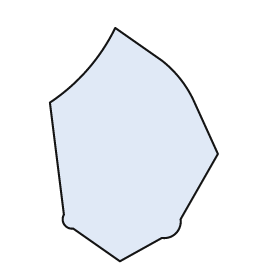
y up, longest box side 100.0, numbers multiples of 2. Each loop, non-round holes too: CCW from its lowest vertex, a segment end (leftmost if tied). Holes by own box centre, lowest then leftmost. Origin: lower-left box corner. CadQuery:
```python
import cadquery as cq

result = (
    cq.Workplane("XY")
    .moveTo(30.0, 0.0)
    .lineTo(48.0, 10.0)
    .threePointArc((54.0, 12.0), (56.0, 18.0))
    .lineTo(72.0, 46.0)
    .lineTo(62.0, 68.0)
    .threePointArc((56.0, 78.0), (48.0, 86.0))
    .lineTo(28.0, 100.0)
    .threePointArc((16.0, 82.0), (0.0, 68.0))
    .lineTo(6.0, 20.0)
    .threePointArc((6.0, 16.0), (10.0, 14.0))
    .close()
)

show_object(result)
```